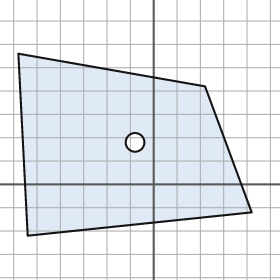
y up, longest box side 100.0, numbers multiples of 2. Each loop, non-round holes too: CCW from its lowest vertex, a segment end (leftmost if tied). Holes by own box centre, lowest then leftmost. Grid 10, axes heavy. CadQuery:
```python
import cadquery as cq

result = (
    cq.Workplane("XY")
    .moveTo(-54.0, -22.0)
    .lineTo(42.0, -12.0)
    .lineTo(22.0, 42.0)
    .lineTo(-58.0, 56.0)
    .close()
    .moveTo(-8.0, 18.0)
    .circle(4.0)
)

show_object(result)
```